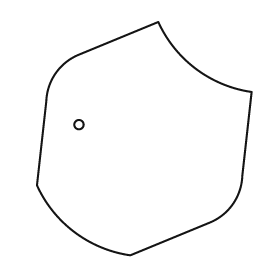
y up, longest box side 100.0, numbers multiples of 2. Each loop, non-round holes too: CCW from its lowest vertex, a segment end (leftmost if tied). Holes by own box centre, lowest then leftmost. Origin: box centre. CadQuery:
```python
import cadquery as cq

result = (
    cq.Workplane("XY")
    .moveTo(-6.0, -50.0)
    .lineTo(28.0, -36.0)
    .threePointArc((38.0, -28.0), (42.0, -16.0))
    .lineTo(46.0, 20.0)
    .threePointArc((22.0, 30.0), (6.0, 50.0))
    .lineTo(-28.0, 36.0)
    .threePointArc((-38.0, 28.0), (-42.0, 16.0))
    .lineTo(-46.0, -20.0)
    .threePointArc((-30.0, -40.0), (-6.0, -50.0))
    .close()
    .moveTo(-28.0, 6.0)
    .circle(2.0)
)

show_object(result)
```